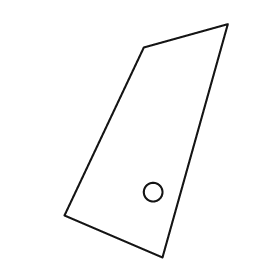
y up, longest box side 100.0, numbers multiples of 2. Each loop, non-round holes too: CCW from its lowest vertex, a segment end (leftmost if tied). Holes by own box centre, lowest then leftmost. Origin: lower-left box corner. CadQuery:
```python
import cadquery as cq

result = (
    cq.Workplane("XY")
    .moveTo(42.0, 0.0)
    .lineTo(70.0, 100.0)
    .lineTo(34.0, 90.0)
    .lineTo(0.0, 18.0)
    .close()
    .moveTo(38.0, 28.0)
    .circle(4.0)
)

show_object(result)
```